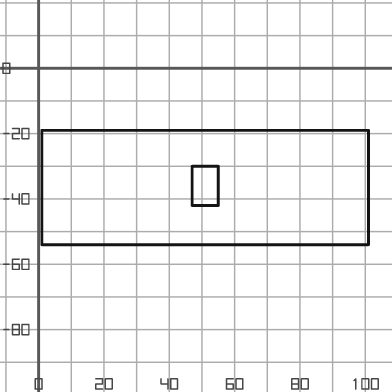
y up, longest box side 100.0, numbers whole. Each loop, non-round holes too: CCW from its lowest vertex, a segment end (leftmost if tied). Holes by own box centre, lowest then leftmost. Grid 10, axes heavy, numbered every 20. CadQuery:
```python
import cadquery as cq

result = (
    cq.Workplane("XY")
    .moveTo(1.0, -54.0)
    .lineTo(101.0, -54.0)
    .lineTo(101.0, -19.0)
    .lineTo(1.0, -19.0)
    .close()
    .moveTo(47.0, -42.0)
    .lineTo(55.0, -42.0)
    .lineTo(55.0, -30.0)
    .lineTo(47.0, -30.0)
    .close()
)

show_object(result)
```